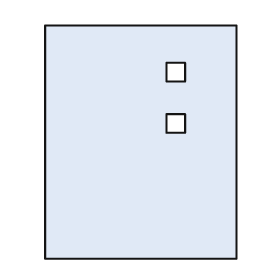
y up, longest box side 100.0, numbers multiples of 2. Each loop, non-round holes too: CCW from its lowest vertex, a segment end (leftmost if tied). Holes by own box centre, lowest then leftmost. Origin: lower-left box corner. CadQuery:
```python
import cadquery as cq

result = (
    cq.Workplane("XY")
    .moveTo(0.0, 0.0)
    .lineTo(82.0, 0.0)
    .lineTo(82.0, 100.0)
    .lineTo(0.0, 100.0)
    .close()
    .moveTo(52.0, 54.0)
    .lineTo(60.0, 54.0)
    .lineTo(60.0, 62.0)
    .lineTo(52.0, 62.0)
    .close()
    .moveTo(52.0, 76.0)
    .lineTo(60.0, 76.0)
    .lineTo(60.0, 84.0)
    .lineTo(52.0, 84.0)
    .close()
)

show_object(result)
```